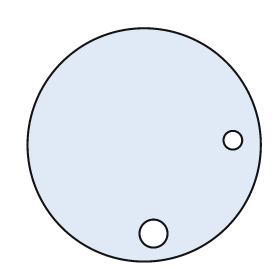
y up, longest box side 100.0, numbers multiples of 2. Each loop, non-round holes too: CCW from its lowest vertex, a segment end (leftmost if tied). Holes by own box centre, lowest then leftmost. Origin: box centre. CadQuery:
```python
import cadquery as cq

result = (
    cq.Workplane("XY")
    .moveTo(0.0, 0.0)
    .circle(50.0)
    .moveTo(4.0, -38.0)
    .circle(6.0)
    .moveTo(38.0, 2.0)
    .circle(4.0)
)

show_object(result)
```